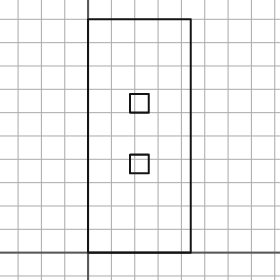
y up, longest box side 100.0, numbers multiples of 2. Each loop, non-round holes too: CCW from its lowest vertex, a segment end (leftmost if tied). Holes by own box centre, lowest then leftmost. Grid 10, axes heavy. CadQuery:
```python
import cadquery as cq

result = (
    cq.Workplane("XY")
    .moveTo(0.0, 0.0)
    .lineTo(44.0, 0.0)
    .lineTo(44.0, 100.0)
    .lineTo(0.0, 100.0)
    .close()
    .moveTo(18.0, 34.0)
    .lineTo(26.0, 34.0)
    .lineTo(26.0, 42.0)
    .lineTo(18.0, 42.0)
    .close()
    .moveTo(18.0, 60.0)
    .lineTo(26.0, 60.0)
    .lineTo(26.0, 68.0)
    .lineTo(18.0, 68.0)
    .close()
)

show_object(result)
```